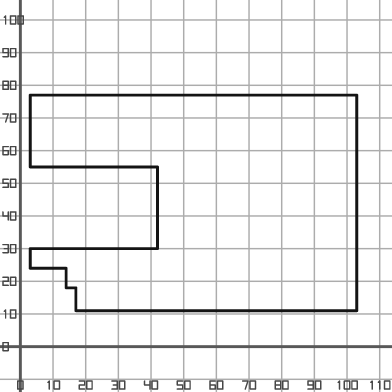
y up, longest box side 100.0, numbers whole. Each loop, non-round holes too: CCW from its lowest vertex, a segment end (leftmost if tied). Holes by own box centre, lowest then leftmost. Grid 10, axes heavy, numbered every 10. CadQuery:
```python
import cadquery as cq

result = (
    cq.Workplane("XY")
    .moveTo(17.0, 11.0)
    .lineTo(103.0, 11.0)
    .lineTo(103.0, 77.0)
    .lineTo(3.0, 77.0)
    .lineTo(3.0, 55.0)
    .lineTo(42.0, 55.0)
    .lineTo(42.0, 30.0)
    .lineTo(3.0, 30.0)
    .lineTo(3.0, 24.0)
    .lineTo(14.0, 24.0)
    .lineTo(14.0, 18.0)
    .lineTo(17.0, 18.0)
    .close()
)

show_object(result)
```